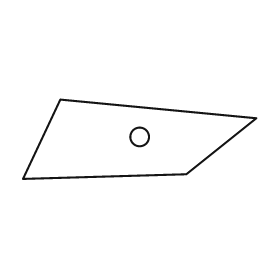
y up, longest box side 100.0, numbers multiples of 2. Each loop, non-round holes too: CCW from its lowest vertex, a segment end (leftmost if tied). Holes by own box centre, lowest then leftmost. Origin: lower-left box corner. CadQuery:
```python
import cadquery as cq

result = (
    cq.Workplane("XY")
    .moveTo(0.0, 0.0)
    .lineTo(70.0, 2.0)
    .lineTo(100.0, 26.0)
    .lineTo(16.0, 34.0)
    .close()
    .moveTo(50.0, 18.0)
    .circle(4.0)
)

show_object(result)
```